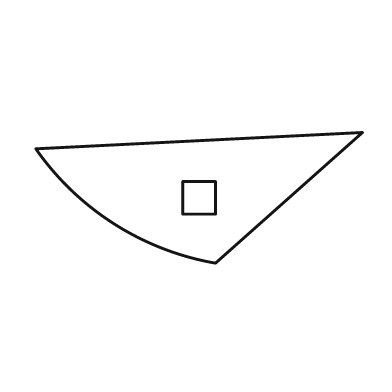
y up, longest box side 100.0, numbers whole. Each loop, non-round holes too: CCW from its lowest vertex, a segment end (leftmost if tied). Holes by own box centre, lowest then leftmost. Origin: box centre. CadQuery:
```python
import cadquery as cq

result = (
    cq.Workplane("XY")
    .moveTo(5.0, -20.0)
    .lineTo(50.0, 20.0)
    .lineTo(-50.0, 15.0)
    .threePointArc((-26.0, -8.0), (5.0, -20.0))
    .close()
    .moveTo(-5.0, -5.0)
    .lineTo(5.0, -5.0)
    .lineTo(5.0, 5.0)
    .lineTo(-5.0, 5.0)
    .close()
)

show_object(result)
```